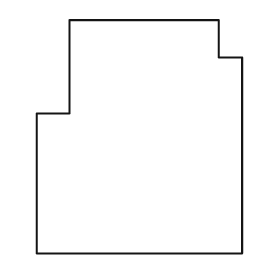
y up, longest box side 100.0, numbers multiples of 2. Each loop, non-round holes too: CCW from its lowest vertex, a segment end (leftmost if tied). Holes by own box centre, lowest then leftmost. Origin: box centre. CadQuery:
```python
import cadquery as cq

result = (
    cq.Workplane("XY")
    .moveTo(-44.0, -50.0)
    .lineTo(44.0, -50.0)
    .lineTo(44.0, 34.0)
    .lineTo(34.0, 34.0)
    .lineTo(34.0, 50.0)
    .lineTo(-30.0, 50.0)
    .lineTo(-30.0, 10.0)
    .lineTo(-44.0, 10.0)
    .close()
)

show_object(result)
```